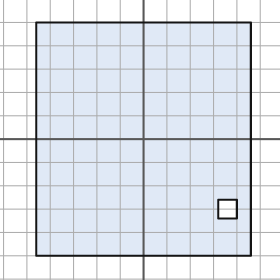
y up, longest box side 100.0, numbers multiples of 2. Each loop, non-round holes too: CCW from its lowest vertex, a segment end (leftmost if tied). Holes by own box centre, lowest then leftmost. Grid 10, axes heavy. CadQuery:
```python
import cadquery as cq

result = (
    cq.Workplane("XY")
    .moveTo(-46.0, -50.0)
    .lineTo(46.0, -50.0)
    .lineTo(46.0, 50.0)
    .lineTo(-46.0, 50.0)
    .close()
    .moveTo(32.0, -34.0)
    .lineTo(40.0, -34.0)
    .lineTo(40.0, -26.0)
    .lineTo(32.0, -26.0)
    .close()
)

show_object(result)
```